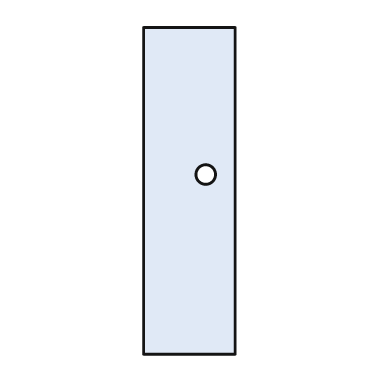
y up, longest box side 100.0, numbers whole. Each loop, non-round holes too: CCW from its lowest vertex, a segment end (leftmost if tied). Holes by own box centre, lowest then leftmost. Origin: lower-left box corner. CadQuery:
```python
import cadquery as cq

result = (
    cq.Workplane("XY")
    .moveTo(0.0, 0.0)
    .lineTo(28.0, 0.0)
    .lineTo(28.0, 100.0)
    .lineTo(0.0, 100.0)
    .close()
    .moveTo(19.0, 55.0)
    .circle(3.0)
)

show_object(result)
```